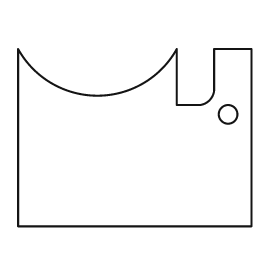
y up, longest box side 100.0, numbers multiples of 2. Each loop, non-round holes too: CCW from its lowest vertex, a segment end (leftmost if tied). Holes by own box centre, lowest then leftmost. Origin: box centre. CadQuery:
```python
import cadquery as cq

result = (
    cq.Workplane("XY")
    .moveTo(-50.0, -38.0)
    .lineTo(50.0, -38.0)
    .lineTo(50.0, 38.0)
    .lineTo(34.0, 38.0)
    .lineTo(34.0, 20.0)
    .threePointArc((32.0, 16.0), (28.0, 14.0))
    .lineTo(18.0, 14.0)
    .lineTo(18.0, 38.0)
    .threePointArc((-16.0, 18.0), (-50.0, 38.0))
    .close()
    .moveTo(40.0, 10.0)
    .circle(4.0)
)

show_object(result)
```